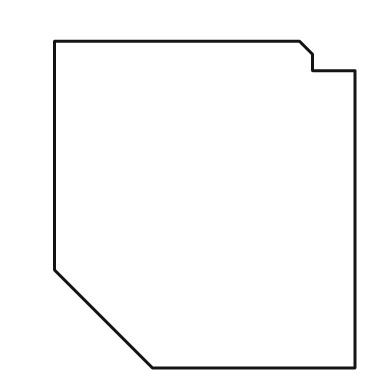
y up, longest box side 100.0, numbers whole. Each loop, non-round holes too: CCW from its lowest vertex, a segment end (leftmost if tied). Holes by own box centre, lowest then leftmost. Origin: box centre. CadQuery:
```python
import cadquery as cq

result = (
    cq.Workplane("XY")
    .moveTo(-16.0, -50.0)
    .lineTo(46.0, -50.0)
    .lineTo(46.0, 41.0)
    .lineTo(33.0, 41.0)
    .lineTo(33.0, 46.0)
    .lineTo(29.0, 50.0)
    .lineTo(-46.0, 50.0)
    .lineTo(-46.0, -20.0)
    .close()
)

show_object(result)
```